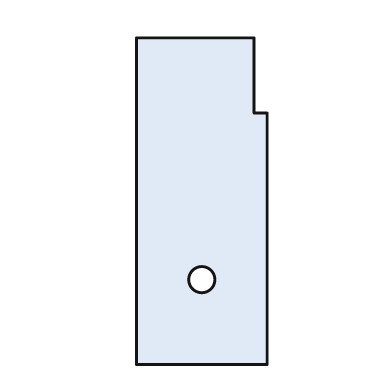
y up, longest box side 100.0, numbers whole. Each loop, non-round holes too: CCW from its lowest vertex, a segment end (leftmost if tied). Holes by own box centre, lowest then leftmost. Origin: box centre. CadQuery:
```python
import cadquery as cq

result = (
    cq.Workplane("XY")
    .moveTo(-20.0, -50.0)
    .lineTo(20.0, -50.0)
    .lineTo(20.0, 27.0)
    .lineTo(16.0, 27.0)
    .lineTo(16.0, 50.0)
    .lineTo(-20.0, 50.0)
    .close()
    .moveTo(0.0, -24.0)
    .circle(4.0)
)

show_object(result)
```